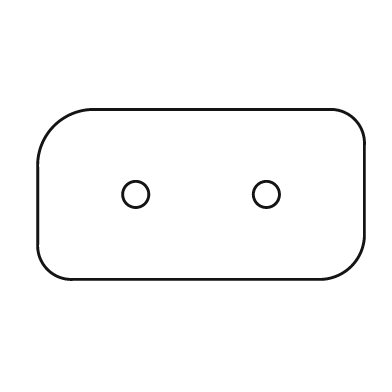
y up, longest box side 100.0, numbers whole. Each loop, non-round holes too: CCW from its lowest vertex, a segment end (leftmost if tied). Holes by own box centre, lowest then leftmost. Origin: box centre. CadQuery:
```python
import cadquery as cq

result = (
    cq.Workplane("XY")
    .moveTo(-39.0, -26.0)
    .lineTo(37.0, -26.0)
    .threePointArc((46.0, -22.0), (50.0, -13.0))
    .lineTo(50.0, 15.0)
    .threePointArc((47.0, 23.0), (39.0, 26.0))
    .lineTo(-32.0, 26.0)
    .threePointArc((-45.0, 21.0), (-50.0, 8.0))
    .lineTo(-50.0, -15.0)
    .threePointArc((-47.0, -23.0), (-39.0, -26.0))
    .close()
    .moveTo(-20.0, 0.0)
    .circle(4.0)
    .moveTo(20.0, 0.0)
    .circle(4.0)
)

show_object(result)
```